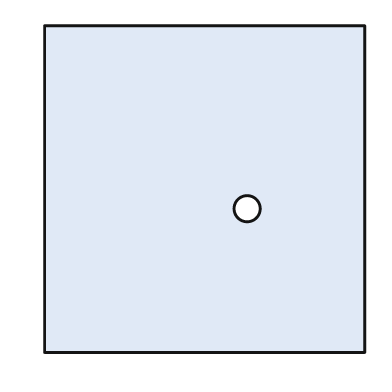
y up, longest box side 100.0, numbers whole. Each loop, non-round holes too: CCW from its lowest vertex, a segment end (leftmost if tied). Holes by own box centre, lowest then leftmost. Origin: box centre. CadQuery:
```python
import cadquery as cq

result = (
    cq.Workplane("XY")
    .moveTo(-49.0, -50.0)
    .lineTo(49.0, -50.0)
    .lineTo(49.0, 50.0)
    .lineTo(-49.0, 50.0)
    .close()
    .moveTo(13.0, -6.0)
    .circle(4.0)
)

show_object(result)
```